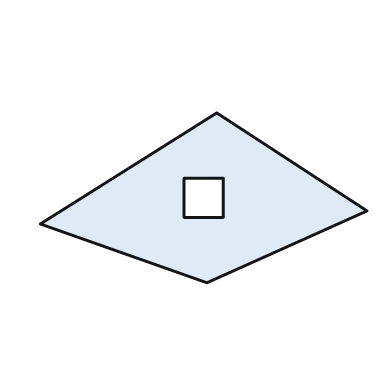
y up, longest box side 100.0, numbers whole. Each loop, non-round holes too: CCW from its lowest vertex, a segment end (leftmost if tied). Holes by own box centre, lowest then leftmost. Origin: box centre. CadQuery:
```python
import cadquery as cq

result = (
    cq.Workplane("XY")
    .moveTo(1.0, -26.0)
    .lineTo(50.0, -4.0)
    .lineTo(4.0, 26.0)
    .lineTo(-50.0, -8.0)
    .close()
    .moveTo(-6.0, -6.0)
    .lineTo(6.0, -6.0)
    .lineTo(6.0, 6.0)
    .lineTo(-6.0, 6.0)
    .close()
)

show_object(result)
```